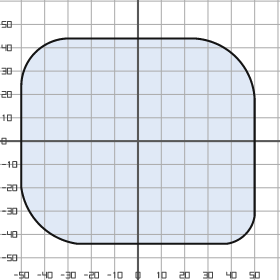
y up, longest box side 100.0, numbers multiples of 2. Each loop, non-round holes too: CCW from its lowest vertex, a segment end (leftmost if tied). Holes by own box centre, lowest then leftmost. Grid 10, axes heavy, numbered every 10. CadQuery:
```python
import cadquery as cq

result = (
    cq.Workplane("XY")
    .moveTo(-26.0, -44.0)
    .lineTo(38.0, -44.0)
    .threePointArc((46.0, -40.0), (50.0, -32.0))
    .lineTo(50.0, 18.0)
    .threePointArc((42.0, 36.0), (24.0, 44.0))
    .lineTo(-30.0, 44.0)
    .threePointArc((-44.0, 38.0), (-50.0, 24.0))
    .lineTo(-50.0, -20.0)
    .threePointArc((-42.0, -36.0), (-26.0, -44.0))
    .close()
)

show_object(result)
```